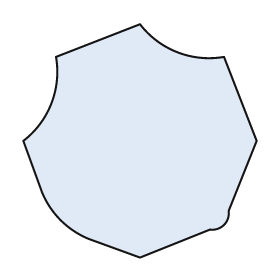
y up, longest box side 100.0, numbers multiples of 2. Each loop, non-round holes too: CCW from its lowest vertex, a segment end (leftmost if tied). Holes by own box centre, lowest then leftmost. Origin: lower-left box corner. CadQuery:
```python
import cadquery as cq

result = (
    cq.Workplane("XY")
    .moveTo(50.0, 0.0)
    .lineTo(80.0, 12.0)
    .threePointArc((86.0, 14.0), (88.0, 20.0))
    .lineTo(100.0, 50.0)
    .lineTo(86.0, 86.0)
    .threePointArc((66.0, 88.0), (50.0, 100.0))
    .lineTo(14.0, 86.0)
    .threePointArc((12.0, 66.0), (0.0, 50.0))
    .lineTo(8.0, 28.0)
    .threePointArc((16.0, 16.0), (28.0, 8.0))
    .close()
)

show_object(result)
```